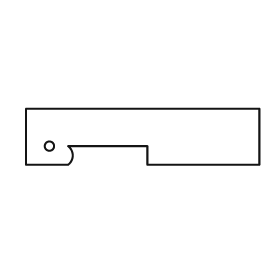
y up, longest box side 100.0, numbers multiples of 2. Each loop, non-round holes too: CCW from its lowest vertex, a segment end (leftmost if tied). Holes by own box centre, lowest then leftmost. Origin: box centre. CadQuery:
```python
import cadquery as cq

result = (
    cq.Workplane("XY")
    .moveTo(-50.0, -12.0)
    .lineTo(-32.0, -12.0)
    .threePointArc((-30.0, -8.0), (-32.0, -4.0))
    .lineTo(2.0, -4.0)
    .lineTo(2.0, -12.0)
    .lineTo(50.0, -12.0)
    .lineTo(50.0, 12.0)
    .lineTo(-50.0, 12.0)
    .close()
    .moveTo(-40.0, -4.0)
    .circle(2.0)
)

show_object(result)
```